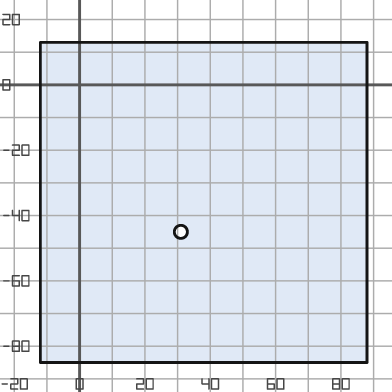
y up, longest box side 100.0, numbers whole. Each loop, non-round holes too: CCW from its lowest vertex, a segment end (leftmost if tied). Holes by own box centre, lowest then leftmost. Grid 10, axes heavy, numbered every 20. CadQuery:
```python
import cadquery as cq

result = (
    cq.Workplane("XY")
    .moveTo(-12.0, -85.0)
    .lineTo(88.0, -85.0)
    .lineTo(88.0, 13.0)
    .lineTo(-12.0, 13.0)
    .close()
    .moveTo(31.0, -45.0)
    .circle(2.0)
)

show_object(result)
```